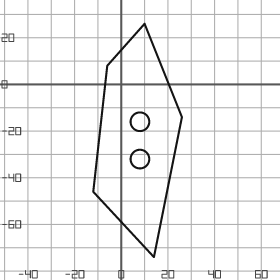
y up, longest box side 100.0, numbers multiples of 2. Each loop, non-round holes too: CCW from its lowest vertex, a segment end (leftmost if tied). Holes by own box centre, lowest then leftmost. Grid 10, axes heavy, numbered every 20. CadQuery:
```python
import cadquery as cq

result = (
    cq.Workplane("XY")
    .moveTo(14.0, -74.0)
    .lineTo(26.0, -14.0)
    .lineTo(10.0, 26.0)
    .lineTo(-6.0, 8.0)
    .lineTo(-12.0, -46.0)
    .close()
    .moveTo(8.0, -32.0)
    .circle(4.0)
    .moveTo(8.0, -16.0)
    .circle(4.0)
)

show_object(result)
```